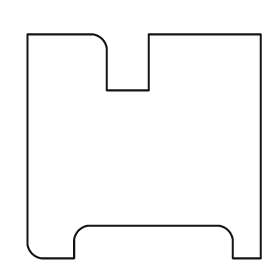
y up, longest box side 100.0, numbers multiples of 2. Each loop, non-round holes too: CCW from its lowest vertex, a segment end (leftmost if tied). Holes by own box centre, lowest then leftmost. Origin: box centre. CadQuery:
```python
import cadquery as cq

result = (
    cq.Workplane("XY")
    .moveTo(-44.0, -48.0)
    .lineTo(-30.0, -48.0)
    .lineTo(-30.0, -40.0)
    .threePointArc((-28.0, -36.0), (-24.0, -34.0))
    .lineTo(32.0, -34.0)
    .threePointArc((36.0, -36.0), (38.0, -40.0))
    .lineTo(38.0, -48.0)
    .lineTo(50.0, -48.0)
    .lineTo(50.0, 48.0)
    .lineTo(2.0, 48.0)
    .lineTo(2.0, 24.0)
    .lineTo(-16.0, 24.0)
    .lineTo(-16.0, 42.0)
    .threePointArc((-18.0, 46.0), (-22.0, 48.0))
    .lineTo(-50.0, 48.0)
    .lineTo(-50.0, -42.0)
    .threePointArc((-48.0, -46.0), (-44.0, -48.0))
    .close()
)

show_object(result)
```